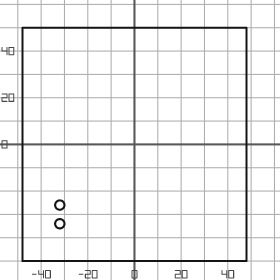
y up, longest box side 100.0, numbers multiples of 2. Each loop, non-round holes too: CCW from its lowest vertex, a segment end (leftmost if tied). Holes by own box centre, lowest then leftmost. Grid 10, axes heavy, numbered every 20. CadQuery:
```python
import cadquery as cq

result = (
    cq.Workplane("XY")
    .moveTo(-48.0, -50.0)
    .lineTo(48.0, -50.0)
    .lineTo(48.0, 50.0)
    .lineTo(-48.0, 50.0)
    .close()
    .moveTo(-32.0, -34.0)
    .circle(2.0)
    .moveTo(-32.0, -26.0)
    .circle(2.0)
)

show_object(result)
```